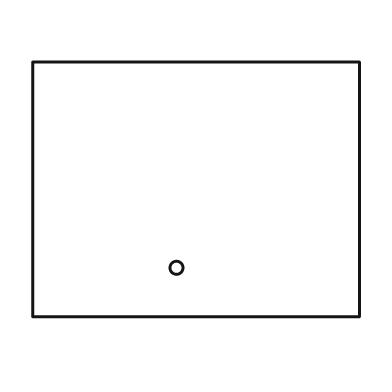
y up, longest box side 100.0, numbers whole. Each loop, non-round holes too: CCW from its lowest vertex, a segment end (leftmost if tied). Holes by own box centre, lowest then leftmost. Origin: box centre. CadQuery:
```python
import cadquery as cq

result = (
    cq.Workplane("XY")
    .moveTo(-50.0, -39.0)
    .lineTo(50.0, -39.0)
    .lineTo(50.0, 39.0)
    .lineTo(-50.0, 39.0)
    .close()
    .moveTo(-6.0, -24.0)
    .circle(2.0)
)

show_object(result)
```